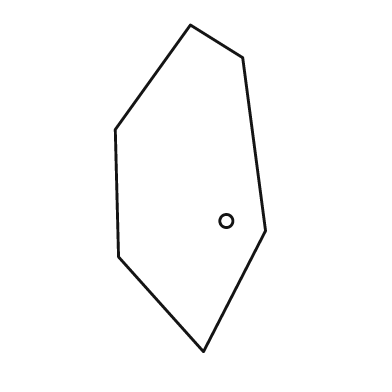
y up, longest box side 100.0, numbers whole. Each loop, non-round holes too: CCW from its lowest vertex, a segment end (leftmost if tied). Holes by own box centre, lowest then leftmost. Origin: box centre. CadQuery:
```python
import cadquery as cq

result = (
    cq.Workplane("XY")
    .moveTo(4.0, -50.0)
    .lineTo(23.0, -13.0)
    .lineTo(16.0, 40.0)
    .lineTo(0.0, 50.0)
    .lineTo(-23.0, 18.0)
    .lineTo(-22.0, -21.0)
    .close()
    .moveTo(11.0, -10.0)
    .circle(2.0)
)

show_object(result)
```